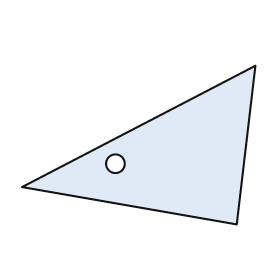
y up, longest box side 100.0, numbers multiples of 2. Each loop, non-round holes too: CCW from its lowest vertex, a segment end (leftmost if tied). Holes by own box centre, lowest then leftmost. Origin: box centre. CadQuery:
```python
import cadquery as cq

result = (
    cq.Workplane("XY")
    .moveTo(42.0, -34.0)
    .lineTo(50.0, 34.0)
    .lineTo(-50.0, -18.0)
    .close()
    .moveTo(-10.0, -8.0)
    .circle(4.0)
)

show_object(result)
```